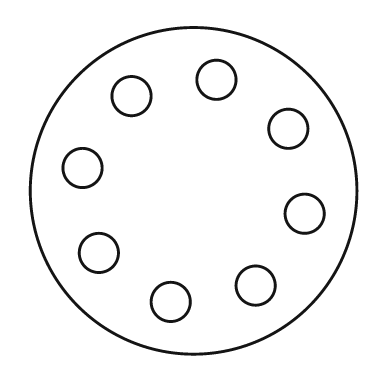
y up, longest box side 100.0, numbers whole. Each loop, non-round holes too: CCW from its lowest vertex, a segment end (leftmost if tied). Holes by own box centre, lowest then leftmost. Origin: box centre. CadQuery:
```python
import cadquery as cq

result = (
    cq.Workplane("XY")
    .moveTo(0.0, 0.0)
    .circle(50.0)
    .moveTo(-7.0, -34.0)
    .circle(6.0)
    .moveTo(19.0, -29.0)
    .circle(6.0)
    .moveTo(-29.0, -19.0)
    .circle(6.0)
    .moveTo(34.0, -7.0)
    .circle(6.0)
    .moveTo(-34.0, 7.0)
    .circle(6.0)
    .moveTo(29.0, 19.0)
    .circle(6.0)
    .moveTo(-19.0, 29.0)
    .circle(6.0)
    .moveTo(7.0, 34.0)
    .circle(6.0)
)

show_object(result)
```